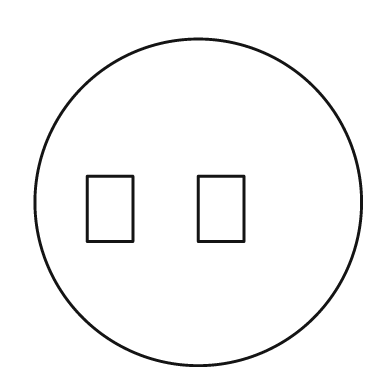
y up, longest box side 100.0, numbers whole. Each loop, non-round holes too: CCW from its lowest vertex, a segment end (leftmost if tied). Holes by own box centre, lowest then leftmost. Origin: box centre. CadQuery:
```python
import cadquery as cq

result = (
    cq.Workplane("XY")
    .moveTo(0.0, 0.0)
    .circle(50.0)
    .moveTo(-34.0, -12.0)
    .lineTo(-20.0, -12.0)
    .lineTo(-20.0, 8.0)
    .lineTo(-34.0, 8.0)
    .close()
    .moveTo(0.0, -12.0)
    .lineTo(14.0, -12.0)
    .lineTo(14.0, 8.0)
    .lineTo(0.0, 8.0)
    .close()
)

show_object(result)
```